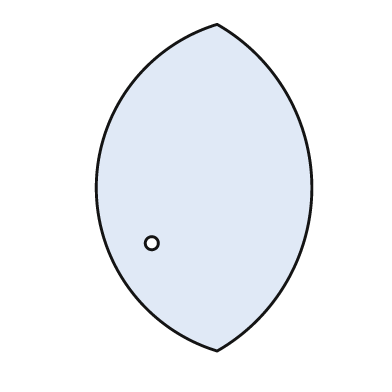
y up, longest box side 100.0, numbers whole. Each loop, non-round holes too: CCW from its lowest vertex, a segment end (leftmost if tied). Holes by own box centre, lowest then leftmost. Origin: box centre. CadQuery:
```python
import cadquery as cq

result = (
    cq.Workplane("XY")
    .moveTo(4.0, -50.0)
    .threePointArc((33.0, 0.0), (4.0, 50.0))
    .threePointArc((-33.0, 0.0), (4.0, -50.0))
    .close()
    .moveTo(-16.0, -17.0)
    .circle(2.0)
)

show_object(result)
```